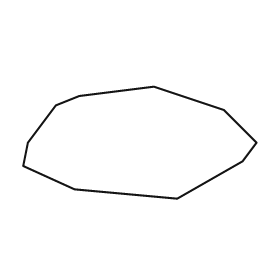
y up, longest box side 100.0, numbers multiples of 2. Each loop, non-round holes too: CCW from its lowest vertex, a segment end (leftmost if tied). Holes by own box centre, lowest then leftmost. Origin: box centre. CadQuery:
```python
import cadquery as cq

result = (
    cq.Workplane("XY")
    .moveTo(16.0, -24.0)
    .lineTo(44.0, -8.0)
    .lineTo(50.0, 0.0)
    .lineTo(36.0, 14.0)
    .lineTo(6.0, 24.0)
    .lineTo(-26.0, 20.0)
    .lineTo(-36.0, 16.0)
    .lineTo(-48.0, 0.0)
    .lineTo(-50.0, -10.0)
    .lineTo(-28.0, -20.0)
    .close()
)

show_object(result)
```